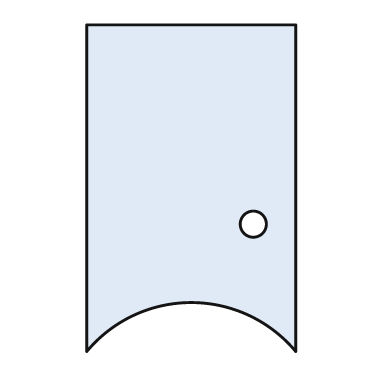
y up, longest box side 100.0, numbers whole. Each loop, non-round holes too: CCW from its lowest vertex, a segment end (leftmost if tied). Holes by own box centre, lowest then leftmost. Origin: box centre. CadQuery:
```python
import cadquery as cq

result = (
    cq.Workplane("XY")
    .moveTo(-32.0, -50.0)
    .threePointArc((0.0, -35.0), (32.0, -50.0))
    .lineTo(32.0, 50.0)
    .lineTo(-32.0, 50.0)
    .close()
    .moveTo(19.0, -11.0)
    .circle(4.0)
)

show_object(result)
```